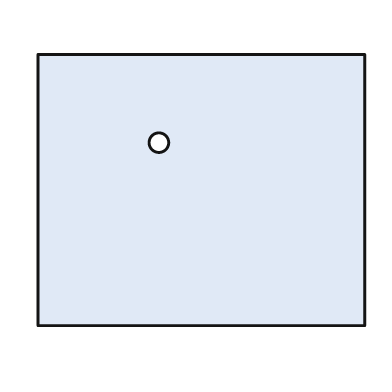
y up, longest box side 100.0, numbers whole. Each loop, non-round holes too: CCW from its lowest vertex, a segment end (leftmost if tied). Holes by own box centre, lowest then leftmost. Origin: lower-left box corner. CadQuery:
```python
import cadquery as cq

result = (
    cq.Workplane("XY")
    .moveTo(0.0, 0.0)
    .lineTo(100.0, 0.0)
    .lineTo(100.0, 83.0)
    .lineTo(0.0, 83.0)
    .close()
    .moveTo(37.0, 56.0)
    .circle(3.0)
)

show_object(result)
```